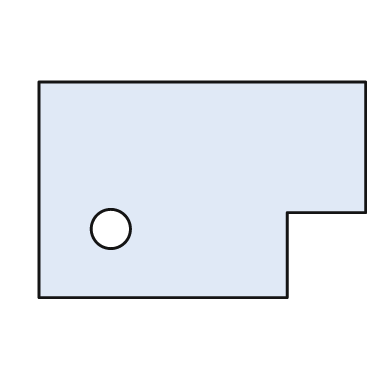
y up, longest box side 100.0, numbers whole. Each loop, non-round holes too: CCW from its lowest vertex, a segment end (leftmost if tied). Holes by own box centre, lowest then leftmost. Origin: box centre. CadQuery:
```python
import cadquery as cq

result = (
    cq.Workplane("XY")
    .moveTo(-50.0, -33.0)
    .lineTo(26.0, -33.0)
    .lineTo(26.0, -7.0)
    .lineTo(50.0, -7.0)
    .lineTo(50.0, 33.0)
    .lineTo(-50.0, 33.0)
    .close()
    .moveTo(-28.0, -12.0)
    .circle(6.0)
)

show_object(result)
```